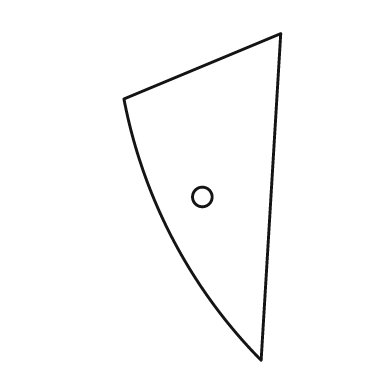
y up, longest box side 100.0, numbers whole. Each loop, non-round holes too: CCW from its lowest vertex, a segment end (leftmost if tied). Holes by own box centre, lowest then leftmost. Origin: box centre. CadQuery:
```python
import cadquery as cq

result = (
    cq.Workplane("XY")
    .moveTo(18.0, -50.0)
    .lineTo(24.0, 50.0)
    .lineTo(-24.0, 30.0)
    .threePointArc((-9.0, -13.0), (18.0, -50.0))
    .close()
    .moveTo(0.0, 0.0)
    .circle(3.0)
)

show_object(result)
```